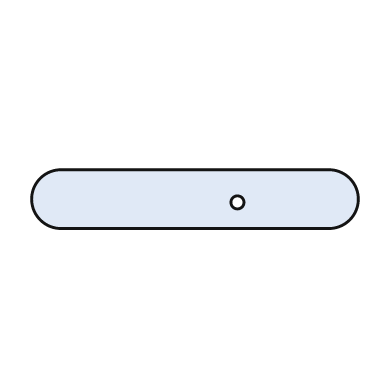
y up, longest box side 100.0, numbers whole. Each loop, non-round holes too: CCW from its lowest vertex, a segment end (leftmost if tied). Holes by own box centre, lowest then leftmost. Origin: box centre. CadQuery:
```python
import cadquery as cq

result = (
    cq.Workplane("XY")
    .moveTo(-41.0, -9.0)
    .lineTo(41.0, -9.0)
    .threePointArc((50.0, 0.0), (41.0, 9.0))
    .lineTo(-41.0, 9.0)
    .threePointArc((-50.0, 0.0), (-41.0, -9.0))
    .close()
    .moveTo(13.0, -1.0)
    .circle(2.0)
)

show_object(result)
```